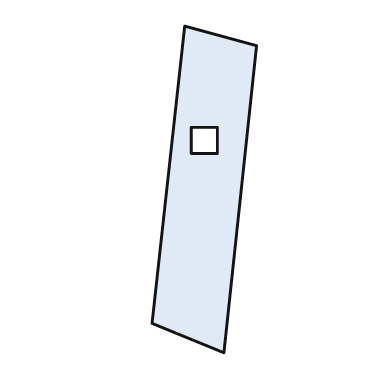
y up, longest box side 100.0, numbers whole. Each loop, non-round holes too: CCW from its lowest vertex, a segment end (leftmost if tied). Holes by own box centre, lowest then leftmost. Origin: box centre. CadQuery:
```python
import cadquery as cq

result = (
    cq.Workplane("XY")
    .moveTo(6.0, -50.0)
    .lineTo(16.0, 44.0)
    .lineTo(-6.0, 50.0)
    .lineTo(-16.0, -41.0)
    .close()
    .moveTo(-4.0, 11.0)
    .lineTo(4.0, 11.0)
    .lineTo(4.0, 19.0)
    .lineTo(-4.0, 19.0)
    .close()
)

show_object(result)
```